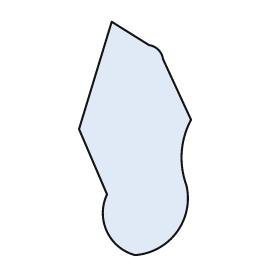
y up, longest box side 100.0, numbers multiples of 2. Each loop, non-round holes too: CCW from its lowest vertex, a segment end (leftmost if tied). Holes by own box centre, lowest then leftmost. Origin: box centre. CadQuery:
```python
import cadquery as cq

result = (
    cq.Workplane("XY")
    .moveTo(0.0, -50.0)
    .threePointArc((18.0, -40.0), (22.0, -20.0))
    .threePointArc((20.0, -6.0), (24.0, 8.0))
    .lineTo(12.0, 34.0)
    .threePointArc((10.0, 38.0), (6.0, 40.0))
    .lineTo(-10.0, 50.0)
    .lineTo(-24.0, 4.0)
    .lineTo(-12.0, -24.0)
    .threePointArc((-12.0, -40.0), (0.0, -50.0))
    .close()
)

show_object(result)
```